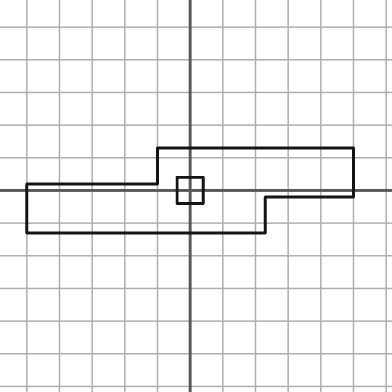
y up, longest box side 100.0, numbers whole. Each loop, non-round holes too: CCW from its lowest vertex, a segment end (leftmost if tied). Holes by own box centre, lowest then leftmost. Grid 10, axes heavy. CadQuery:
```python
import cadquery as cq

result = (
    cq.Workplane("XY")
    .moveTo(-50.0, -13.0)
    .lineTo(23.0, -13.0)
    .lineTo(23.0, -2.0)
    .lineTo(50.0, -2.0)
    .lineTo(50.0, 13.0)
    .lineTo(-10.0, 13.0)
    .lineTo(-10.0, 2.0)
    .lineTo(-50.0, 2.0)
    .close()
    .moveTo(-4.0, -4.0)
    .lineTo(4.0, -4.0)
    .lineTo(4.0, 4.0)
    .lineTo(-4.0, 4.0)
    .close()
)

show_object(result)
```